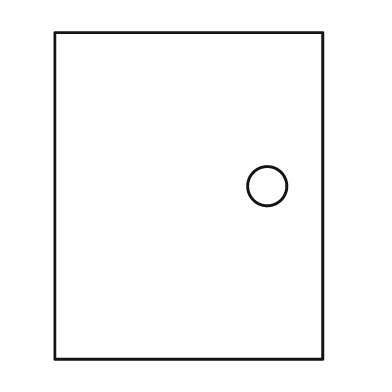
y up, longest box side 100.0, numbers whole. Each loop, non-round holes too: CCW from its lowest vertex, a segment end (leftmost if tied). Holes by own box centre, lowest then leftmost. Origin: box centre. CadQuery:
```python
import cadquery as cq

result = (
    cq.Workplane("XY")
    .moveTo(-41.0, -50.0)
    .lineTo(41.0, -50.0)
    .lineTo(41.0, 50.0)
    .lineTo(-41.0, 50.0)
    .close()
    .moveTo(24.0, 3.0)
    .circle(6.0)
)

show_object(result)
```